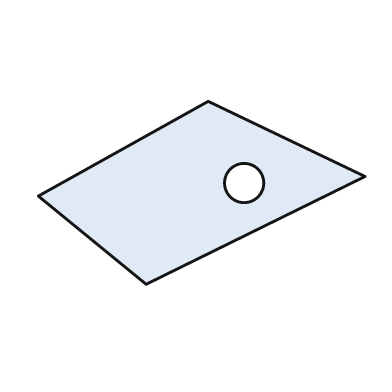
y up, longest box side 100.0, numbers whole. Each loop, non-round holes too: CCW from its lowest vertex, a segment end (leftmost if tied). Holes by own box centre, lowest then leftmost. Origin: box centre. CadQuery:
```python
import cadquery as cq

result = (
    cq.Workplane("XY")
    .moveTo(-17.0, -28.0)
    .lineTo(50.0, 5.0)
    .lineTo(2.0, 28.0)
    .lineTo(-50.0, -1.0)
    .close()
    .moveTo(13.0, 3.0)
    .circle(6.0)
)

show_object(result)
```